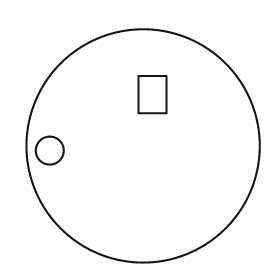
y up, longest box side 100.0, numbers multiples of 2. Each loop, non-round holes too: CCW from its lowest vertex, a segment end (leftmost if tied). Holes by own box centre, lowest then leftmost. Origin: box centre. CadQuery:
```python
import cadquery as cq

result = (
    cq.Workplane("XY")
    .moveTo(0.0, 0.0)
    .circle(50.0)
    .moveTo(-40.0, -2.0)
    .circle(6.0)
    .moveTo(-2.0, 14.0)
    .lineTo(10.0, 14.0)
    .lineTo(10.0, 30.0)
    .lineTo(-2.0, 30.0)
    .close()
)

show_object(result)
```